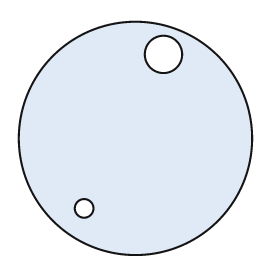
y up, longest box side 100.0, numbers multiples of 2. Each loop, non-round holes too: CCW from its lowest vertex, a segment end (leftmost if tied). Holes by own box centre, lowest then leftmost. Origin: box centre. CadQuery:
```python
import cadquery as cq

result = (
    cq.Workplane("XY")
    .moveTo(0.0, 0.0)
    .circle(50.0)
    .moveTo(-22.0, -30.0)
    .circle(4.0)
    .moveTo(12.0, 36.0)
    .circle(8.0)
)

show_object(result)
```